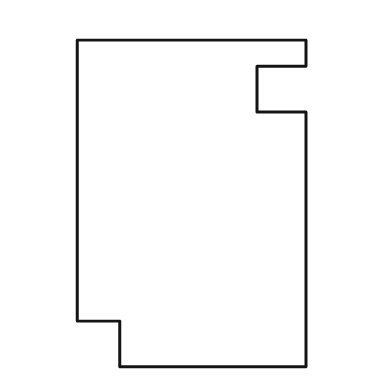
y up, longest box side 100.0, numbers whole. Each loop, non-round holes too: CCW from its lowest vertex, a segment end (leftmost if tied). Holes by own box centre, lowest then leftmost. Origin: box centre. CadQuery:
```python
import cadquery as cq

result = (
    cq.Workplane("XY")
    .moveTo(-22.0, -50.0)
    .lineTo(35.0, -50.0)
    .lineTo(35.0, 28.0)
    .lineTo(20.0, 28.0)
    .lineTo(20.0, 42.0)
    .lineTo(35.0, 42.0)
    .lineTo(35.0, 50.0)
    .lineTo(-35.0, 50.0)
    .lineTo(-35.0, -36.0)
    .lineTo(-22.0, -36.0)
    .close()
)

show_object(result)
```